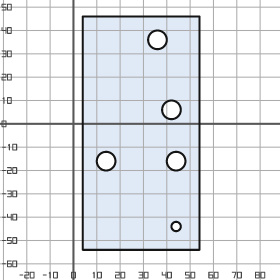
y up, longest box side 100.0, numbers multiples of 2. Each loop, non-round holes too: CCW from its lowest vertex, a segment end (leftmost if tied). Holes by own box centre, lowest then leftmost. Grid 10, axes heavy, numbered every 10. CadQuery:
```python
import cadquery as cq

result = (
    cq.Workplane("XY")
    .moveTo(4.0, -54.0)
    .lineTo(54.0, -54.0)
    .lineTo(54.0, 46.0)
    .lineTo(4.0, 46.0)
    .close()
    .moveTo(44.0, -44.0)
    .circle(2.0)
    .moveTo(14.0, -16.0)
    .circle(4.0)
    .moveTo(44.0, -16.0)
    .circle(4.0)
    .moveTo(42.0, 6.0)
    .circle(4.0)
    .moveTo(36.0, 36.0)
    .circle(4.0)
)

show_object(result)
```